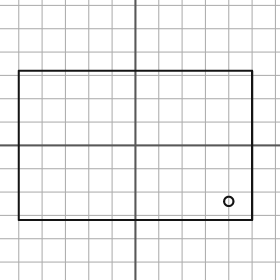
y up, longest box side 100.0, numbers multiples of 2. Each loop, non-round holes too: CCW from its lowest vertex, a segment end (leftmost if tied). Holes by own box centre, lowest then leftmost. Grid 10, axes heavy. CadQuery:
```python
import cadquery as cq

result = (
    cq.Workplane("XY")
    .moveTo(-50.0, -32.0)
    .lineTo(50.0, -32.0)
    .lineTo(50.0, 32.0)
    .lineTo(-50.0, 32.0)
    .close()
    .moveTo(40.0, -24.0)
    .circle(2.0)
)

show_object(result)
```